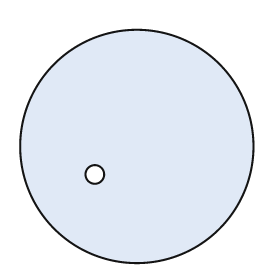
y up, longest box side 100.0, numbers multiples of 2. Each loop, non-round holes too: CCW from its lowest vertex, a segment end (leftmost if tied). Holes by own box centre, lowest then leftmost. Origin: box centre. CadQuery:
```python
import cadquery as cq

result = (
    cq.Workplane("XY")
    .moveTo(0.0, 0.0)
    .circle(50.0)
    .moveTo(-18.0, -12.0)
    .circle(4.0)
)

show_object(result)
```